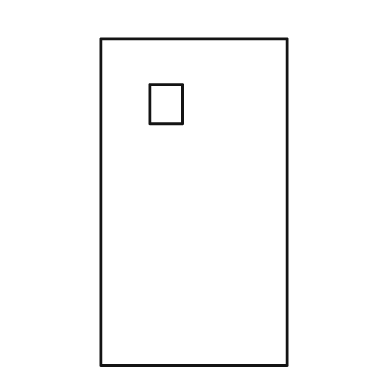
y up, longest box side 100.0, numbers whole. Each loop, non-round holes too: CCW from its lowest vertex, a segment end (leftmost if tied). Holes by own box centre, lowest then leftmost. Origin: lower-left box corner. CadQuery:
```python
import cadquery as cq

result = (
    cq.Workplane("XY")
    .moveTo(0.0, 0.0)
    .lineTo(57.0, 0.0)
    .lineTo(57.0, 100.0)
    .lineTo(0.0, 100.0)
    .close()
    .moveTo(15.0, 74.0)
    .lineTo(25.0, 74.0)
    .lineTo(25.0, 86.0)
    .lineTo(15.0, 86.0)
    .close()
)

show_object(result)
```